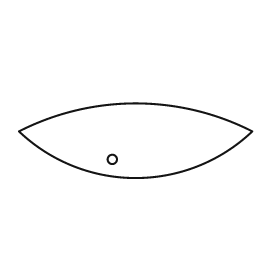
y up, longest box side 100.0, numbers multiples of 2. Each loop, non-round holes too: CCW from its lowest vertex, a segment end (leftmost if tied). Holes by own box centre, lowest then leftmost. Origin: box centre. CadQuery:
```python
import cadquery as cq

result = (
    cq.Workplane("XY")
    .moveTo(-50.0, 4.0)
    .threePointArc((0.0, -16.0), (50.0, 4.0))
    .threePointArc((0.0, 16.0), (-50.0, 4.0))
    .close()
    .moveTo(-10.0, -8.0)
    .circle(2.0)
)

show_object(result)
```